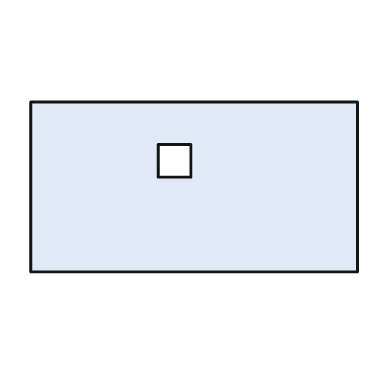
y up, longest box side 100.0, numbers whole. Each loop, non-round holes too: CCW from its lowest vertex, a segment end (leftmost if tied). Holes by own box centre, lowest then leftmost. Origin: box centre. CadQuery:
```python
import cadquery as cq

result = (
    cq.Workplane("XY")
    .moveTo(-50.0, -26.0)
    .lineTo(50.0, -26.0)
    .lineTo(50.0, 26.0)
    .lineTo(-50.0, 26.0)
    .close()
    .moveTo(-11.0, 3.0)
    .lineTo(-1.0, 3.0)
    .lineTo(-1.0, 13.0)
    .lineTo(-11.0, 13.0)
    .close()
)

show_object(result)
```